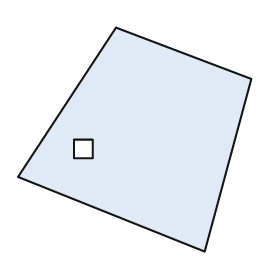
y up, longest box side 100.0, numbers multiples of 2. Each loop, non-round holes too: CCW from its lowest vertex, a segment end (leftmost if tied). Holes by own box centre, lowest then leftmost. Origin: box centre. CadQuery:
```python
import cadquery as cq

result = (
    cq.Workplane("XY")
    .moveTo(30.0, -48.0)
    .lineTo(50.0, 26.0)
    .lineTo(-8.0, 48.0)
    .lineTo(-50.0, -16.0)
    .close()
    .moveTo(-26.0, -8.0)
    .lineTo(-18.0, -8.0)
    .lineTo(-18.0, 0.0)
    .lineTo(-26.0, 0.0)
    .close()
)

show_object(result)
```